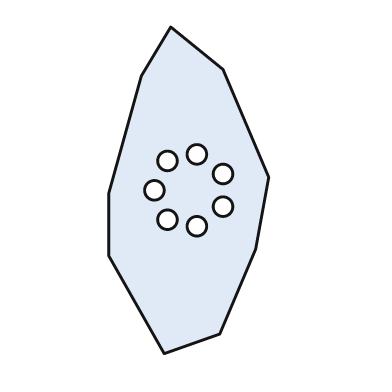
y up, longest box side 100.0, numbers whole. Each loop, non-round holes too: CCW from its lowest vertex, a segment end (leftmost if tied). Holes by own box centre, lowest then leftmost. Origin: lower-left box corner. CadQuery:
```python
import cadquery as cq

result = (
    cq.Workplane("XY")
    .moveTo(17.0, 0.0)
    .lineTo(34.0, 6.0)
    .lineTo(45.0, 32.0)
    .lineTo(49.0, 54.0)
    .lineTo(35.0, 87.0)
    .lineTo(19.0, 100.0)
    .lineTo(10.0, 85.0)
    .lineTo(0.0, 49.0)
    .lineTo(0.0, 30.0)
    .close()
    .moveTo(27.0, 39.0)
    .circle(3.0)
    .moveTo(18.0, 41.0)
    .circle(3.0)
    .moveTo(35.0, 45.0)
    .circle(3.0)
    .moveTo(14.0, 50.0)
    .circle(3.0)
    .moveTo(35.0, 55.0)
    .circle(3.0)
    .moveTo(18.0, 59.0)
    .circle(3.0)
    .moveTo(27.0, 61.0)
    .circle(3.0)
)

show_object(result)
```